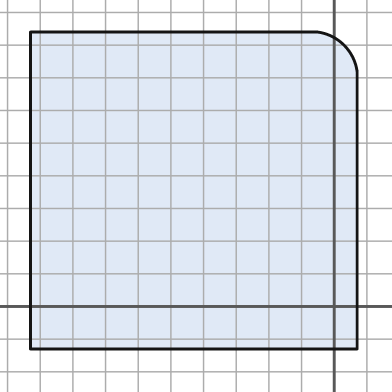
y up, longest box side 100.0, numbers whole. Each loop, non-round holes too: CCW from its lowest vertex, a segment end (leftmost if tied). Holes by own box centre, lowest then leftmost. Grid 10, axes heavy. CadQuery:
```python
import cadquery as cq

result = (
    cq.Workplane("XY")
    .moveTo(-93.0, -13.0)
    .lineTo(7.0, -13.0)
    .lineTo(7.0, 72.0)
    .threePointArc((3.0, 80.0), (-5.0, 84.0))
    .lineTo(-93.0, 84.0)
    .close()
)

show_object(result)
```